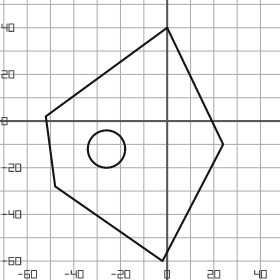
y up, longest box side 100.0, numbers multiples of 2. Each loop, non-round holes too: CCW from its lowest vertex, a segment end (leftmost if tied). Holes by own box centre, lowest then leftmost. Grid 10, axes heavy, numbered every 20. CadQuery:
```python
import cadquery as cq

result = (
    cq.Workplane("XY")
    .moveTo(-2.0, -60.0)
    .lineTo(24.0, -10.0)
    .lineTo(0.0, 40.0)
    .lineTo(-52.0, 2.0)
    .lineTo(-48.0, -28.0)
    .close()
    .moveTo(-26.0, -12.0)
    .circle(8.0)
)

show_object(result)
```